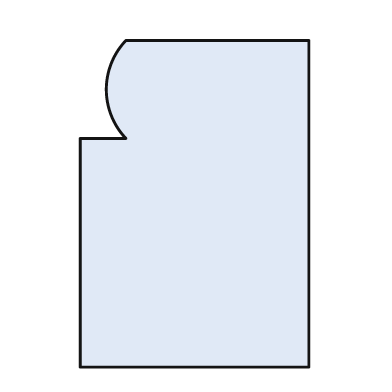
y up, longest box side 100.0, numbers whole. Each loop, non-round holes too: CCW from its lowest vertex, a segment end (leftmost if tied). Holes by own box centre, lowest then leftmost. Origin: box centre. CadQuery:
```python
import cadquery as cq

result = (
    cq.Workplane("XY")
    .moveTo(-35.0, -50.0)
    .lineTo(35.0, -50.0)
    .lineTo(35.0, 50.0)
    .lineTo(-21.0, 50.0)
    .threePointArc((-27.0, 35.0), (-21.0, 20.0))
    .lineTo(-35.0, 20.0)
    .close()
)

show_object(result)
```